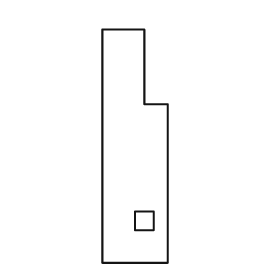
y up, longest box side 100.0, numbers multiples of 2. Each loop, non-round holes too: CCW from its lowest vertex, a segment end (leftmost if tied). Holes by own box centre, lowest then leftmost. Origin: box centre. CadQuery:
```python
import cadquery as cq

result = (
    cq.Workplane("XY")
    .moveTo(-14.0, -50.0)
    .lineTo(14.0, -50.0)
    .lineTo(14.0, 18.0)
    .lineTo(4.0, 18.0)
    .lineTo(4.0, 50.0)
    .lineTo(-14.0, 50.0)
    .close()
    .moveTo(0.0, -36.0)
    .lineTo(8.0, -36.0)
    .lineTo(8.0, -28.0)
    .lineTo(0.0, -28.0)
    .close()
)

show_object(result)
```